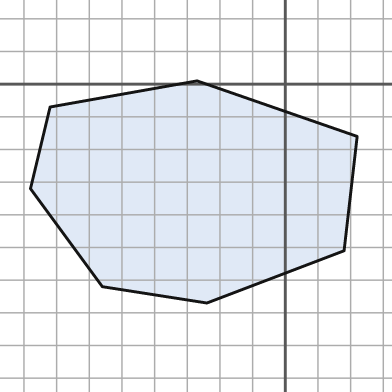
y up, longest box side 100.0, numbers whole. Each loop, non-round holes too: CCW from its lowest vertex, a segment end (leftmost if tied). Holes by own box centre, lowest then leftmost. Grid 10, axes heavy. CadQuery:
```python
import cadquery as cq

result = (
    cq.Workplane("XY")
    .moveTo(-24.0, -67.0)
    .lineTo(18.0, -51.0)
    .lineTo(22.0, -16.0)
    .lineTo(-27.0, 1.0)
    .lineTo(-72.0, -7.0)
    .lineTo(-78.0, -32.0)
    .lineTo(-56.0, -62.0)
    .close()
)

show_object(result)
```